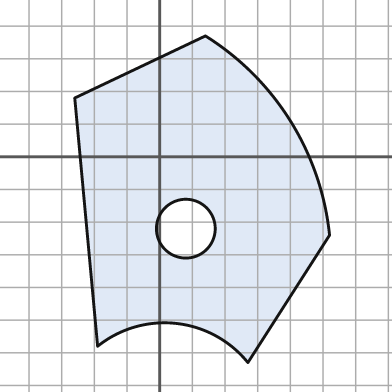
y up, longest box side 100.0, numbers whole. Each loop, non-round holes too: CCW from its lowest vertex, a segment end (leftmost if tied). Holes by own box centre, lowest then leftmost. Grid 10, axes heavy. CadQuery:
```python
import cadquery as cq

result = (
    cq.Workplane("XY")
    .moveTo(27.0, -63.0)
    .lineTo(52.0, -24.0)
    .threePointArc((40.0, 11.0), (14.0, 37.0))
    .lineTo(-26.0, 18.0)
    .lineTo(-19.0, -58.0)
    .threePointArc((5.0, -51.0), (27.0, -63.0))
    .close()
    .moveTo(8.0, -22.0)
    .circle(9.0)
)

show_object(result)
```